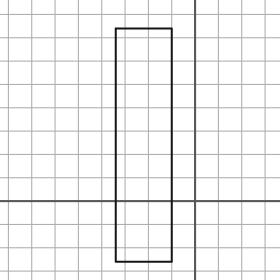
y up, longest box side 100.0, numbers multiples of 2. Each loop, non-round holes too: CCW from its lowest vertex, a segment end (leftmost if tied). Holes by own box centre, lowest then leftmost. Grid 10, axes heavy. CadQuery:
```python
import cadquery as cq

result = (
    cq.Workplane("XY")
    .moveTo(-34.0, -26.0)
    .lineTo(-10.0, -26.0)
    .lineTo(-10.0, 74.0)
    .lineTo(-34.0, 74.0)
    .close()
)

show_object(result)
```